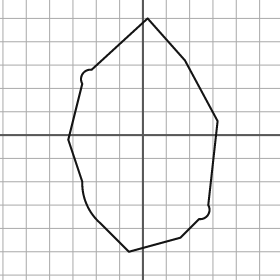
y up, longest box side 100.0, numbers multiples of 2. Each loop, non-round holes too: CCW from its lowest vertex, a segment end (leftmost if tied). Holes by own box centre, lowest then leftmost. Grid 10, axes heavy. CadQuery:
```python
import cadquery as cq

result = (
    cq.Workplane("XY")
    .moveTo(-6.0, -50.0)
    .lineTo(16.0, -44.0)
    .lineTo(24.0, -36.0)
    .threePointArc((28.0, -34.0), (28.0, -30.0))
    .lineTo(32.0, 6.0)
    .lineTo(18.0, 32.0)
    .lineTo(2.0, 50.0)
    .lineTo(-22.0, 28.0)
    .threePointArc((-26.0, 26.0), (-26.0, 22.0))
    .lineTo(-32.0, -2.0)
    .lineTo(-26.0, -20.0)
    .threePointArc((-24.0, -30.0), (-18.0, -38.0))
    .close()
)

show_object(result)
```